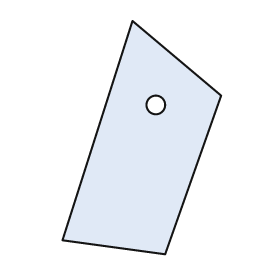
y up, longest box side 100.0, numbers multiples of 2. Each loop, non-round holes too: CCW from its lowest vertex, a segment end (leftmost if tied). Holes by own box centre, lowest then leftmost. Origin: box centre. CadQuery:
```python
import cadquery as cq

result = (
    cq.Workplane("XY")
    .moveTo(10.0, -50.0)
    .lineTo(34.0, 18.0)
    .lineTo(-4.0, 50.0)
    .lineTo(-34.0, -44.0)
    .close()
    .moveTo(6.0, 14.0)
    .circle(4.0)
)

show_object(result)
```